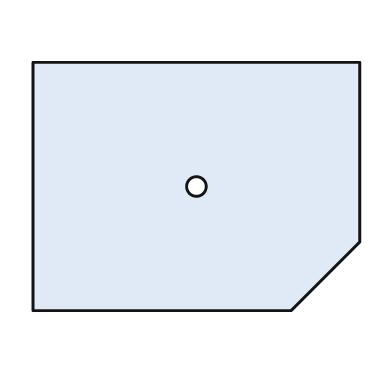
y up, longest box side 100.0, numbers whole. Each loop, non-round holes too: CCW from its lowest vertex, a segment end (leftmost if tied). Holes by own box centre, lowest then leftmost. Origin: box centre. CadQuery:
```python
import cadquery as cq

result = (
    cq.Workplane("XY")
    .moveTo(-50.0, -38.0)
    .lineTo(29.0, -38.0)
    .lineTo(50.0, -17.0)
    .lineTo(50.0, 38.0)
    .lineTo(-50.0, 38.0)
    .close()
    .moveTo(0.0, 0.0)
    .circle(3.0)
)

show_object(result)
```